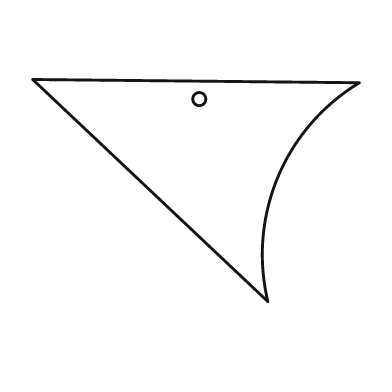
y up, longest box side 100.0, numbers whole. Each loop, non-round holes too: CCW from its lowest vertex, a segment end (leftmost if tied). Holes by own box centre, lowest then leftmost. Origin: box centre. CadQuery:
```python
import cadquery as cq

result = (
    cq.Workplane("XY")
    .moveTo(22.0, -34.0)
    .threePointArc((25.0, 4.0), (50.0, 33.0))
    .lineTo(-50.0, 34.0)
    .close()
    .moveTo(1.0, 28.0)
    .circle(2.0)
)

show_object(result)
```